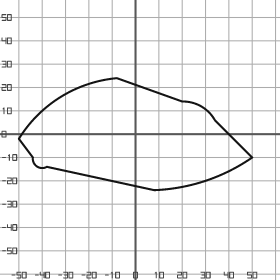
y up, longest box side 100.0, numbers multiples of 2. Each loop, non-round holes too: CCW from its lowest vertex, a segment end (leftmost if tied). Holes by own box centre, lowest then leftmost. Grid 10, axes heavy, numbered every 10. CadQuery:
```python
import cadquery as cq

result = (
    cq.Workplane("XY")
    .moveTo(8.0, -24.0)
    .threePointArc((30.0, -20.0), (50.0, -10.0))
    .lineTo(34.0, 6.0)
    .threePointArc((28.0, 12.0), (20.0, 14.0))
    .lineTo(-8.0, 24.0)
    .threePointArc((-32.0, 16.0), (-50.0, -2.0))
    .lineTo(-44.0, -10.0)
    .threePointArc((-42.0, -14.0), (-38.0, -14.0))
    .close()
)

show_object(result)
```